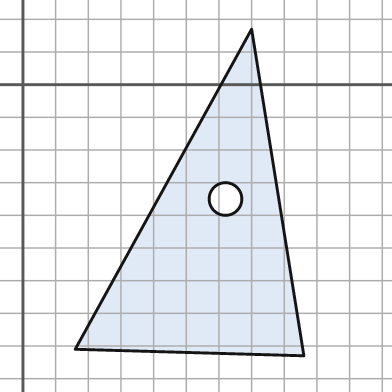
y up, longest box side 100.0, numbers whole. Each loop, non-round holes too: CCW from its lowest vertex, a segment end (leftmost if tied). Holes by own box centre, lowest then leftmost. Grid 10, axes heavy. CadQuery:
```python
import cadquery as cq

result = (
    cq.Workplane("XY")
    .moveTo(86.0, -83.0)
    .lineTo(70.0, 17.0)
    .lineTo(16.0, -81.0)
    .close()
    .moveTo(62.0, -35.0)
    .circle(5.0)
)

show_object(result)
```